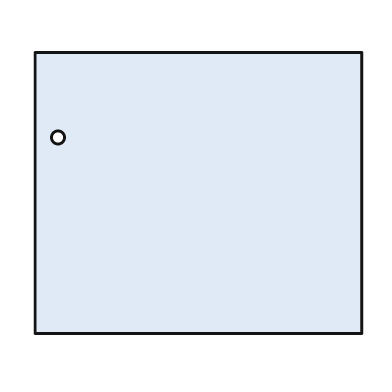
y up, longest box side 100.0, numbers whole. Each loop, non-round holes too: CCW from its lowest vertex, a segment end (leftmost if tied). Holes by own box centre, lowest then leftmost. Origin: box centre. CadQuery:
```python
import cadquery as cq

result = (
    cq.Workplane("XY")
    .moveTo(-50.0, -43.0)
    .lineTo(50.0, -43.0)
    .lineTo(50.0, 43.0)
    .lineTo(-50.0, 43.0)
    .close()
    .moveTo(-43.0, 17.0)
    .circle(2.0)
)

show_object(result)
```